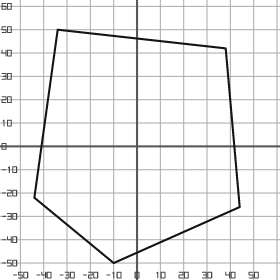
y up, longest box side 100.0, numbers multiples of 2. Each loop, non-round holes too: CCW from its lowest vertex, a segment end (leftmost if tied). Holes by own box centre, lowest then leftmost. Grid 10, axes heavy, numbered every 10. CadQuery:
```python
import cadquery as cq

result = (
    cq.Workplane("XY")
    .moveTo(-10.0, -50.0)
    .lineTo(44.0, -26.0)
    .lineTo(38.0, 42.0)
    .lineTo(-34.0, 50.0)
    .lineTo(-44.0, -22.0)
    .close()
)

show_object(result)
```